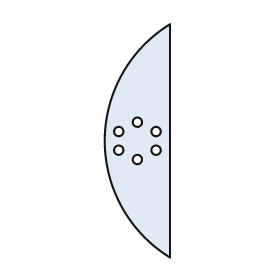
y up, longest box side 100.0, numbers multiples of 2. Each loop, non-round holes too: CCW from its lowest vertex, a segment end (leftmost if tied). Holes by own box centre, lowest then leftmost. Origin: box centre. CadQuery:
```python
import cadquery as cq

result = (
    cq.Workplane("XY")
    .moveTo(14.0, -50.0)
    .lineTo(14.0, 50.0)
    .threePointArc((-14.0, 0.0), (14.0, -50.0))
    .close()
    .moveTo(0.0, -8.0)
    .circle(2.0)
    .moveTo(-8.0, -4.0)
    .circle(2.0)
    .moveTo(8.0, -4.0)
    .circle(2.0)
    .moveTo(-8.0, 4.0)
    .circle(2.0)
    .moveTo(8.0, 4.0)
    .circle(2.0)
    .moveTo(0.0, 8.0)
    .circle(2.0)
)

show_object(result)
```